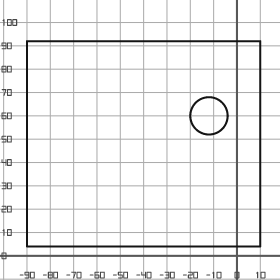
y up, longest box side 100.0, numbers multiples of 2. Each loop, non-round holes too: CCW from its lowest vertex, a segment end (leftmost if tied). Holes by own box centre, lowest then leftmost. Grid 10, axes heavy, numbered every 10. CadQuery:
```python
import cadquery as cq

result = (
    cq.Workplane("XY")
    .moveTo(-90.0, 4.0)
    .lineTo(10.0, 4.0)
    .lineTo(10.0, 92.0)
    .lineTo(-90.0, 92.0)
    .close()
    .moveTo(-12.0, 60.0)
    .circle(8.0)
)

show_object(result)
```